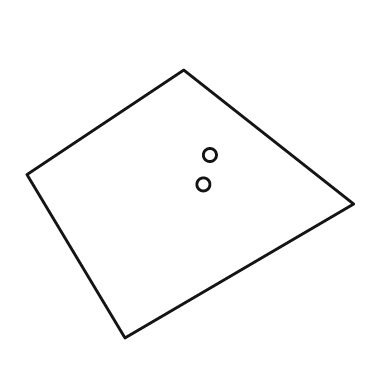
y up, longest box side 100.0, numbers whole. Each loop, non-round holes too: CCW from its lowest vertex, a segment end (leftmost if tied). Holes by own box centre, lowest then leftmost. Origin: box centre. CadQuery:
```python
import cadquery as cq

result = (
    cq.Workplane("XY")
    .moveTo(-20.0, -41.0)
    .lineTo(50.0, 0.0)
    .lineTo(-2.0, 41.0)
    .lineTo(-50.0, 9.0)
    .close()
    .moveTo(4.0, 6.0)
    .circle(2.0)
    .moveTo(6.0, 15.0)
    .circle(2.0)
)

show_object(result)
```